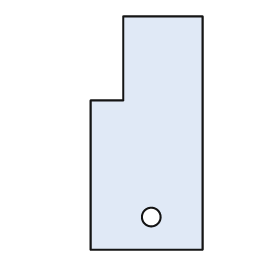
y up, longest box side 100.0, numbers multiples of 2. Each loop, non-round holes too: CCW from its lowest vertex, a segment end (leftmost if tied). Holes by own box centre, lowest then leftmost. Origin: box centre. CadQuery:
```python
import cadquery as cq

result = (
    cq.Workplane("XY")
    .moveTo(-24.0, -50.0)
    .lineTo(24.0, -50.0)
    .lineTo(24.0, 50.0)
    .lineTo(-10.0, 50.0)
    .lineTo(-10.0, 14.0)
    .lineTo(-24.0, 14.0)
    .close()
    .moveTo(2.0, -36.0)
    .circle(4.0)
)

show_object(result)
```